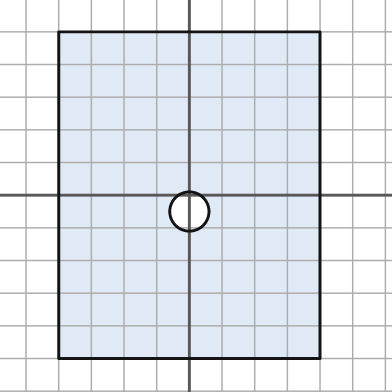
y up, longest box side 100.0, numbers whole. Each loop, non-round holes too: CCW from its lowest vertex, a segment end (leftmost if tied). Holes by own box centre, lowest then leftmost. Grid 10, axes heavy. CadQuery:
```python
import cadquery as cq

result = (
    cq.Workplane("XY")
    .moveTo(-40.0, -50.0)
    .lineTo(40.0, -50.0)
    .lineTo(40.0, 50.0)
    .lineTo(-40.0, 50.0)
    .close()
    .moveTo(0.0, -5.0)
    .circle(6.0)
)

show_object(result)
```